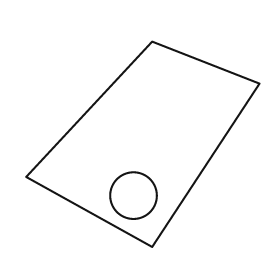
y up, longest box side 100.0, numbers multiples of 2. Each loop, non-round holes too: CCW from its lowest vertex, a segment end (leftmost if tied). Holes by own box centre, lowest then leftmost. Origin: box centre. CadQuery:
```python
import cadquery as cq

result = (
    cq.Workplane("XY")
    .moveTo(4.0, -44.0)
    .lineTo(50.0, 26.0)
    .lineTo(4.0, 44.0)
    .lineTo(-50.0, -14.0)
    .close()
    .moveTo(-4.0, -22.0)
    .circle(10.0)
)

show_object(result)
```